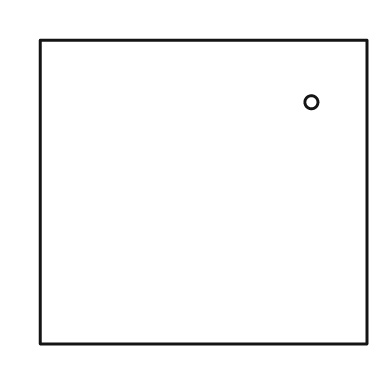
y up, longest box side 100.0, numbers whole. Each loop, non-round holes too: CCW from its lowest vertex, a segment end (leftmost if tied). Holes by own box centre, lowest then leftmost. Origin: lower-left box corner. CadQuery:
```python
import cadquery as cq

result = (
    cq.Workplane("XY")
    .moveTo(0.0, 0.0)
    .lineTo(100.0, 0.0)
    .lineTo(100.0, 93.0)
    .lineTo(0.0, 93.0)
    .close()
    .moveTo(83.0, 74.0)
    .circle(2.0)
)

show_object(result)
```